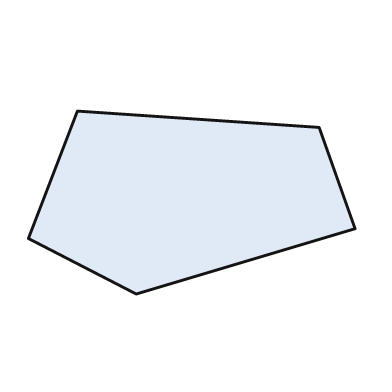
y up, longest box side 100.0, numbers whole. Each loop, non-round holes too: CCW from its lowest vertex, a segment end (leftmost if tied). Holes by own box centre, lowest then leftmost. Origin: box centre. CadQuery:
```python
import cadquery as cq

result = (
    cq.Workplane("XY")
    .moveTo(-17.0, -28.0)
    .lineTo(50.0, -8.0)
    .lineTo(39.0, 23.0)
    .lineTo(-35.0, 28.0)
    .lineTo(-50.0, -11.0)
    .close()
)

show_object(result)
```